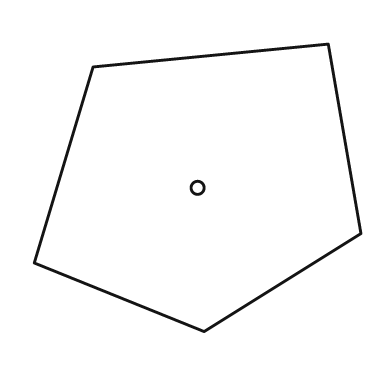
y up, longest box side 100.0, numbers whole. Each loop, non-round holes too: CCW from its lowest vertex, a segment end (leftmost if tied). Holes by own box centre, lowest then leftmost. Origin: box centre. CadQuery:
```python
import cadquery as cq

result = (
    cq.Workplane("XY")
    .moveTo(2.0, -44.0)
    .lineTo(50.0, -14.0)
    .lineTo(40.0, 44.0)
    .lineTo(-32.0, 37.0)
    .lineTo(-50.0, -23.0)
    .close()
    .moveTo(0.0, 0.0)
    .circle(2.0)
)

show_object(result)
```